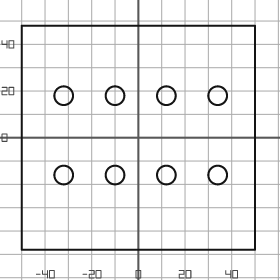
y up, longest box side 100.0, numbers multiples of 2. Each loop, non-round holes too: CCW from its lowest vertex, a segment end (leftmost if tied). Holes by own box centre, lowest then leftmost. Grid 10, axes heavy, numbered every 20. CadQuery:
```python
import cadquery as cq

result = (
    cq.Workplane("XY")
    .moveTo(-50.0, -48.0)
    .lineTo(50.0, -48.0)
    .lineTo(50.0, 48.0)
    .lineTo(-50.0, 48.0)
    .close()
    .moveTo(-32.0, -16.0)
    .circle(4.0)
    .moveTo(-10.0, -16.0)
    .circle(4.0)
    .moveTo(12.0, -16.0)
    .circle(4.0)
    .moveTo(34.0, -16.0)
    .circle(4.0)
    .moveTo(-32.0, 18.0)
    .circle(4.0)
    .moveTo(-10.0, 18.0)
    .circle(4.0)
    .moveTo(12.0, 18.0)
    .circle(4.0)
    .moveTo(34.0, 18.0)
    .circle(4.0)
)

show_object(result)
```